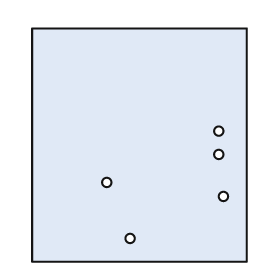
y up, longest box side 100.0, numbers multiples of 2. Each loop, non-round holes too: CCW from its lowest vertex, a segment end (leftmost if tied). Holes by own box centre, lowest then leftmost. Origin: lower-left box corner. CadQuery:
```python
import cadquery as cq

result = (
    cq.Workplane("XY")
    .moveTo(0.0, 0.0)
    .lineTo(92.0, 0.0)
    .lineTo(92.0, 100.0)
    .lineTo(0.0, 100.0)
    .close()
    .moveTo(42.0, 10.0)
    .circle(2.0)
    .moveTo(82.0, 28.0)
    .circle(2.0)
    .moveTo(32.0, 34.0)
    .circle(2.0)
    .moveTo(80.0, 46.0)
    .circle(2.0)
    .moveTo(80.0, 56.0)
    .circle(2.0)
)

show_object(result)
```